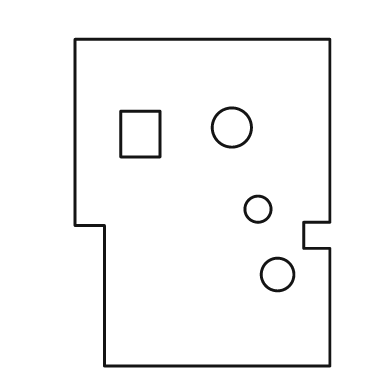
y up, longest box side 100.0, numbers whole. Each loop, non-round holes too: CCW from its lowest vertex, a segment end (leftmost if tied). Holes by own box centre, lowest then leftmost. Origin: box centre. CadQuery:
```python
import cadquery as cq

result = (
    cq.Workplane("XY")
    .moveTo(-30.0, -50.0)
    .lineTo(39.0, -50.0)
    .lineTo(39.0, -14.0)
    .lineTo(31.0, -14.0)
    .lineTo(31.0, -6.0)
    .lineTo(39.0, -6.0)
    .lineTo(39.0, 50.0)
    .lineTo(-39.0, 50.0)
    .lineTo(-39.0, -7.0)
    .lineTo(-30.0, -7.0)
    .close()
    .moveTo(23.0, -22.0)
    .circle(5.0)
    .moveTo(17.0, -2.0)
    .circle(4.0)
    .moveTo(-25.0, 14.0)
    .lineTo(-13.0, 14.0)
    .lineTo(-13.0, 28.0)
    .lineTo(-25.0, 28.0)
    .close()
    .moveTo(9.0, 23.0)
    .circle(6.0)
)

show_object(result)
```